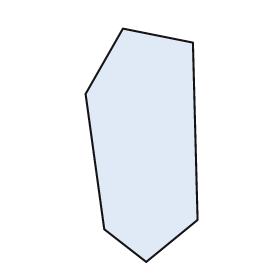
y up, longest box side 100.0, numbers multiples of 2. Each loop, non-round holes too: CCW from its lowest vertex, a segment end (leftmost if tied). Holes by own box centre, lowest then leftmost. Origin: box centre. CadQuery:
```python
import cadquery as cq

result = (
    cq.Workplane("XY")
    .moveTo(2.0, -50.0)
    .lineTo(24.0, -32.0)
    .lineTo(22.0, 44.0)
    .lineTo(-8.0, 50.0)
    .lineTo(-24.0, 22.0)
    .lineTo(-16.0, -36.0)
    .close()
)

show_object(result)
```